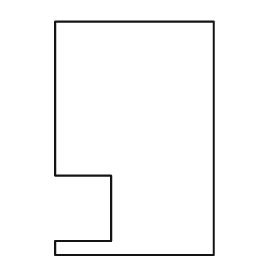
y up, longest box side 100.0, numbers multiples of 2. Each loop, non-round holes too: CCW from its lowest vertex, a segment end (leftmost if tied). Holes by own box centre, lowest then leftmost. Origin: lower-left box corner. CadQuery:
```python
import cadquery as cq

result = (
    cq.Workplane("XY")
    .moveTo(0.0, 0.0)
    .lineTo(68.0, 0.0)
    .lineTo(68.0, 100.0)
    .lineTo(0.0, 100.0)
    .lineTo(0.0, 34.0)
    .lineTo(24.0, 34.0)
    .lineTo(24.0, 6.0)
    .lineTo(0.0, 6.0)
    .close()
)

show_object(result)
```